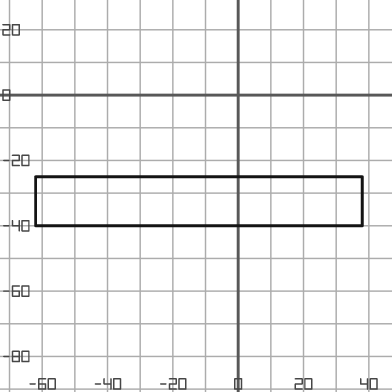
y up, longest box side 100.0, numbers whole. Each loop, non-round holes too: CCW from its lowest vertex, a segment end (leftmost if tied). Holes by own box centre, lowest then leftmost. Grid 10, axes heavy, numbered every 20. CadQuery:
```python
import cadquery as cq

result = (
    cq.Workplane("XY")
    .moveTo(-62.0, -40.0)
    .lineTo(38.0, -40.0)
    .lineTo(38.0, -25.0)
    .lineTo(-62.0, -25.0)
    .close()
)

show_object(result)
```